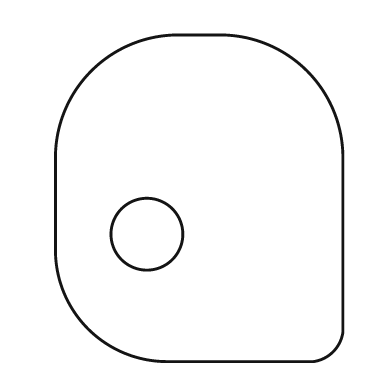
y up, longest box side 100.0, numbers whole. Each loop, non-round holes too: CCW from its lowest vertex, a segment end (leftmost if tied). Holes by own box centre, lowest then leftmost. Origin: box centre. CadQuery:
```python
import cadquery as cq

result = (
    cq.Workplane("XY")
    .moveTo(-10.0, -50.0)
    .lineTo(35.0, -50.0)
    .threePointArc((41.0, -47.0), (44.0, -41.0))
    .lineTo(44.0, 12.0)
    .threePointArc((33.0, 39.0), (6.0, 50.0))
    .lineTo(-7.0, 50.0)
    .threePointArc((-33.0, 39.0), (-44.0, 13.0))
    .lineTo(-44.0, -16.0)
    .threePointArc((-34.0, -40.0), (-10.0, -50.0))
    .close()
    .moveTo(-16.0, -11.0)
    .circle(11.0)
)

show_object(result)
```